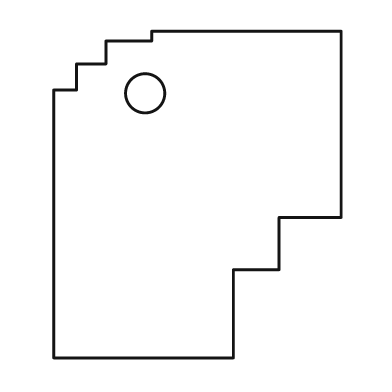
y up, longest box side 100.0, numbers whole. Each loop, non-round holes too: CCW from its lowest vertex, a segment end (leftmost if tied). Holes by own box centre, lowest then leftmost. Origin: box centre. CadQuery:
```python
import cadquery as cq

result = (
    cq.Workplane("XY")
    .moveTo(-44.0, -50.0)
    .lineTo(11.0, -50.0)
    .lineTo(11.0, -23.0)
    .lineTo(25.0, -23.0)
    .lineTo(25.0, -7.0)
    .lineTo(44.0, -7.0)
    .lineTo(44.0, 50.0)
    .lineTo(-14.0, 50.0)
    .lineTo(-14.0, 47.0)
    .lineTo(-28.0, 47.0)
    .lineTo(-28.0, 40.0)
    .lineTo(-37.0, 40.0)
    .lineTo(-37.0, 32.0)
    .lineTo(-44.0, 32.0)
    .close()
    .moveTo(-16.0, 31.0)
    .circle(6.0)
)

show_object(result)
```